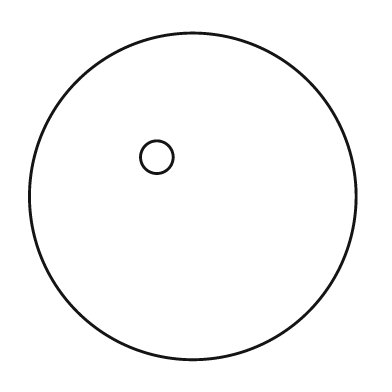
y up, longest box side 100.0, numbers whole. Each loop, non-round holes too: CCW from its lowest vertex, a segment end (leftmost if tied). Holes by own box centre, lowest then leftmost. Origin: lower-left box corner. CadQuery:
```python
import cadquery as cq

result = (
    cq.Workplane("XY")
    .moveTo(50.0, 50.0)
    .circle(50.0)
    .moveTo(39.0, 62.0)
    .circle(5.0)
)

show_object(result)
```